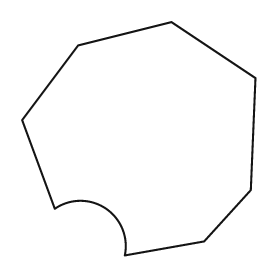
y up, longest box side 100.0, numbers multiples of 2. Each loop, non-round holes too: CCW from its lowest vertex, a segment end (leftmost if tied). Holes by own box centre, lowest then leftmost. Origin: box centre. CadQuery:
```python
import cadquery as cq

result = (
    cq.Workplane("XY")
    .moveTo(-6.0, -50.0)
    .lineTo(28.0, -44.0)
    .lineTo(48.0, -22.0)
    .lineTo(50.0, 26.0)
    .lineTo(14.0, 50.0)
    .lineTo(-26.0, 40.0)
    .lineTo(-50.0, 8.0)
    .lineTo(-36.0, -30.0)
    .threePointArc((-14.0, -30.0), (-6.0, -50.0))
    .close()
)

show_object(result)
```